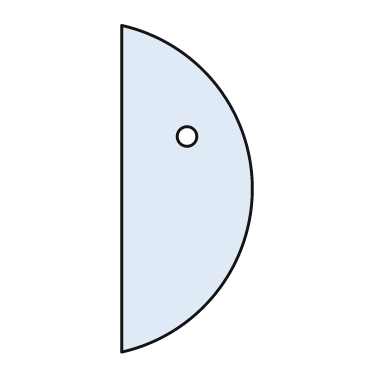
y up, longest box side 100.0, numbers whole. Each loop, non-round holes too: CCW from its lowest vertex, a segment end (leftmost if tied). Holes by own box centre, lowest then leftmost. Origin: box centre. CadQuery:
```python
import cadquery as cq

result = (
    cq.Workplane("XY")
    .moveTo(-20.0, -50.0)
    .threePointArc((20.0, 0.0), (-20.0, 50.0))
    .close()
    .moveTo(0.0, 16.0)
    .circle(3.0)
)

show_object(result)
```